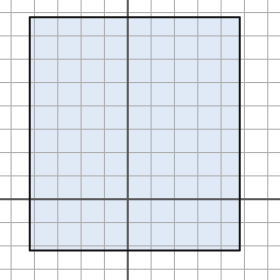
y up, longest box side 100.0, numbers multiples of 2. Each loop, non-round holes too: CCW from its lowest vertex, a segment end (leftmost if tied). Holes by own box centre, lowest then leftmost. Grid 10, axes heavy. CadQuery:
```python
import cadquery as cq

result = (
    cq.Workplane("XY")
    .moveTo(-42.0, -22.0)
    .lineTo(48.0, -22.0)
    .lineTo(48.0, 78.0)
    .lineTo(-42.0, 78.0)
    .close()
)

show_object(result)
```